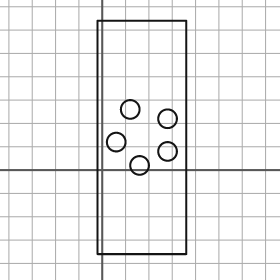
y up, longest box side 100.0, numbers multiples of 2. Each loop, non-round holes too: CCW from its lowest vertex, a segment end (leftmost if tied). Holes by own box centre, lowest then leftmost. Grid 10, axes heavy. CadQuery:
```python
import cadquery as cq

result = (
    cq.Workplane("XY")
    .moveTo(-2.0, -36.0)
    .lineTo(36.0, -36.0)
    .lineTo(36.0, 64.0)
    .lineTo(-2.0, 64.0)
    .close()
    .moveTo(16.0, 2.0)
    .circle(4.0)
    .moveTo(28.0, 8.0)
    .circle(4.0)
    .moveTo(6.0, 12.0)
    .circle(4.0)
    .moveTo(28.0, 22.0)
    .circle(4.0)
    .moveTo(12.0, 26.0)
    .circle(4.0)
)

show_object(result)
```